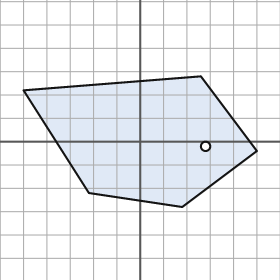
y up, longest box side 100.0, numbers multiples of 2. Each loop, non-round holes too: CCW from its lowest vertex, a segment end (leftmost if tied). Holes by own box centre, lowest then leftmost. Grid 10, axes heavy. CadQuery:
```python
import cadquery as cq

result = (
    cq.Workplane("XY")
    .moveTo(18.0, -28.0)
    .lineTo(50.0, -4.0)
    .lineTo(26.0, 28.0)
    .lineTo(-50.0, 22.0)
    .lineTo(-22.0, -22.0)
    .close()
    .moveTo(28.0, -2.0)
    .circle(2.0)
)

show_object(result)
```